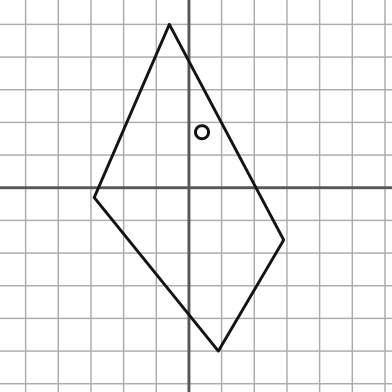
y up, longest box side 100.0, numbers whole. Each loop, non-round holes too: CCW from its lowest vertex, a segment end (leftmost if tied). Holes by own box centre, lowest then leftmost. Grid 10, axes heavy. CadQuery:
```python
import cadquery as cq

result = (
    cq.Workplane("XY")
    .moveTo(9.0, -50.0)
    .lineTo(29.0, -16.0)
    .lineTo(-6.0, 50.0)
    .lineTo(-29.0, -3.0)
    .close()
    .moveTo(4.0, 17.0)
    .circle(2.0)
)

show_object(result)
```